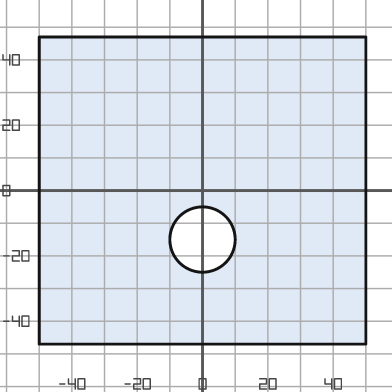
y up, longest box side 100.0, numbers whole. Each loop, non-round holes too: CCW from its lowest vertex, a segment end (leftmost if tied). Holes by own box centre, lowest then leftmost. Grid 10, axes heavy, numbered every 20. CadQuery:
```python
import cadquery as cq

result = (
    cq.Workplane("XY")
    .moveTo(-50.0, -47.0)
    .lineTo(50.0, -47.0)
    .lineTo(50.0, 47.0)
    .lineTo(-50.0, 47.0)
    .close()
    .moveTo(0.0, -15.0)
    .circle(10.0)
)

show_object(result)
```